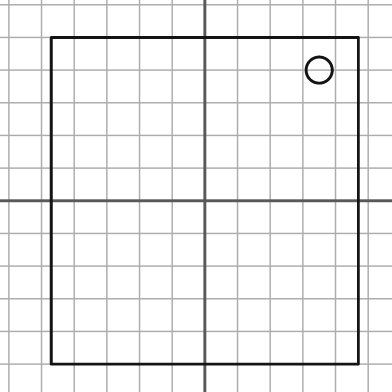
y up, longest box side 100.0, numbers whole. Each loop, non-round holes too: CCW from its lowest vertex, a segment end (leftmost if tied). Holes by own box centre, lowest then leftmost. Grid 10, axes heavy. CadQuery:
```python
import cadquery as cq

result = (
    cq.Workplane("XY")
    .moveTo(-47.0, -50.0)
    .lineTo(47.0, -50.0)
    .lineTo(47.0, 50.0)
    .lineTo(-47.0, 50.0)
    .close()
    .moveTo(35.0, 40.0)
    .circle(4.0)
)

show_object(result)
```